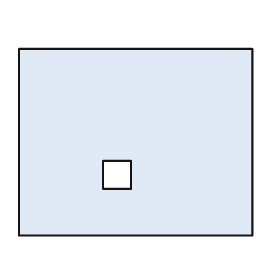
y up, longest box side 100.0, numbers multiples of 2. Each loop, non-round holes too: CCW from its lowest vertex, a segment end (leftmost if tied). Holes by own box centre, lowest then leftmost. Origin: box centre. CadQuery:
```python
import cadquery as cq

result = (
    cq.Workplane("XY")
    .moveTo(-50.0, -40.0)
    .lineTo(50.0, -40.0)
    .lineTo(50.0, 40.0)
    .lineTo(-50.0, 40.0)
    .close()
    .moveTo(-14.0, -20.0)
    .lineTo(-2.0, -20.0)
    .lineTo(-2.0, -8.0)
    .lineTo(-14.0, -8.0)
    .close()
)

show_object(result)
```